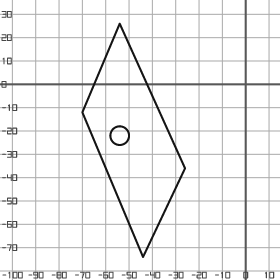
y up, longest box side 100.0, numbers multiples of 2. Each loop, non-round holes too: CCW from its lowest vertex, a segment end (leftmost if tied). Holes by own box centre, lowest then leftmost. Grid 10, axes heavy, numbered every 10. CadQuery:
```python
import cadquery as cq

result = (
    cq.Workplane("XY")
    .moveTo(-44.0, -74.0)
    .lineTo(-26.0, -36.0)
    .lineTo(-54.0, 26.0)
    .lineTo(-70.0, -12.0)
    .close()
    .moveTo(-54.0, -22.0)
    .circle(4.0)
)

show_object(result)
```